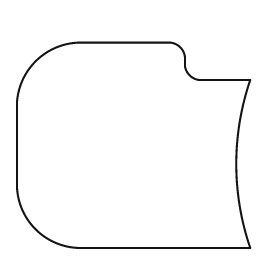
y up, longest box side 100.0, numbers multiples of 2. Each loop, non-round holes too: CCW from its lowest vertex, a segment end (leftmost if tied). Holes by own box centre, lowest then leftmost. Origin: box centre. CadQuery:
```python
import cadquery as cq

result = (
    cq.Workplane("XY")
    .moveTo(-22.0, -44.0)
    .lineTo(50.0, -44.0)
    .threePointArc((44.0, -8.0), (50.0, 28.0))
    .lineTo(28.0, 28.0)
    .threePointArc((24.0, 30.0), (22.0, 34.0))
    .lineTo(22.0, 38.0)
    .threePointArc((20.0, 42.0), (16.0, 44.0))
    .lineTo(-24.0, 44.0)
    .threePointArc((-42.0, 36.0), (-50.0, 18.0))
    .lineTo(-50.0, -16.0)
    .threePointArc((-42.0, -36.0), (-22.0, -44.0))
    .close()
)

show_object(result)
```